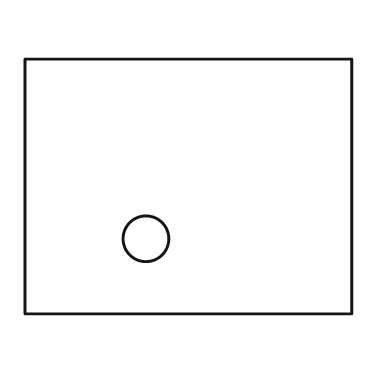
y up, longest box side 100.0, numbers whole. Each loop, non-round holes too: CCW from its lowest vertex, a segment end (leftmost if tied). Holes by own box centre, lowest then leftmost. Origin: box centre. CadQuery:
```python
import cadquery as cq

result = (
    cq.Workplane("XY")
    .moveTo(-50.0, -39.0)
    .lineTo(50.0, -39.0)
    .lineTo(50.0, 39.0)
    .lineTo(-50.0, 39.0)
    .close()
    .moveTo(-13.0, -16.0)
    .circle(7.0)
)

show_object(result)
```